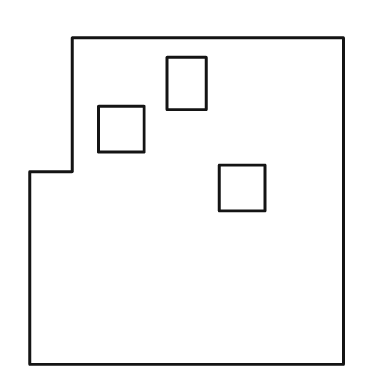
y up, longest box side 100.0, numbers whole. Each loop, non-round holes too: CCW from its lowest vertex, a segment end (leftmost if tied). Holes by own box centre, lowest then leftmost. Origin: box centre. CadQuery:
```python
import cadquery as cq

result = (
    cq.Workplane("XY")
    .moveTo(-48.0, -50.0)
    .lineTo(48.0, -50.0)
    .lineTo(48.0, 50.0)
    .lineTo(-35.0, 50.0)
    .lineTo(-35.0, 9.0)
    .lineTo(-48.0, 9.0)
    .close()
    .moveTo(10.0, -3.0)
    .lineTo(24.0, -3.0)
    .lineTo(24.0, 11.0)
    .lineTo(10.0, 11.0)
    .close()
    .moveTo(-27.0, 15.0)
    .lineTo(-13.0, 15.0)
    .lineTo(-13.0, 29.0)
    .lineTo(-27.0, 29.0)
    .close()
    .moveTo(-6.0, 28.0)
    .lineTo(6.0, 28.0)
    .lineTo(6.0, 44.0)
    .lineTo(-6.0, 44.0)
    .close()
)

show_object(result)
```